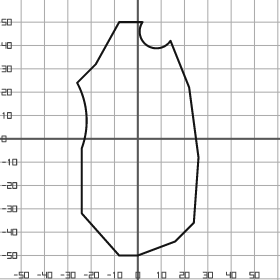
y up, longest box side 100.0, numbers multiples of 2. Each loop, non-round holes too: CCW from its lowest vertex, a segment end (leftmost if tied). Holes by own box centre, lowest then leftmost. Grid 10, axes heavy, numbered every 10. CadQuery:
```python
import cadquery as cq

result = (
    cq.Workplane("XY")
    .moveTo(-8.0, -50.0)
    .lineTo(0.0, -50.0)
    .lineTo(16.0, -44.0)
    .lineTo(24.0, -36.0)
    .lineTo(26.0, -8.0)
    .lineTo(22.0, 22.0)
    .lineTo(14.0, 42.0)
    .threePointArc((4.0, 40.0), (2.0, 50.0))
    .lineTo(-8.0, 50.0)
    .lineTo(-18.0, 32.0)
    .lineTo(-26.0, 24.0)
    .threePointArc((-22.0, 10.0), (-24.0, -4.0))
    .lineTo(-24.0, -32.0)
    .close()
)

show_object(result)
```